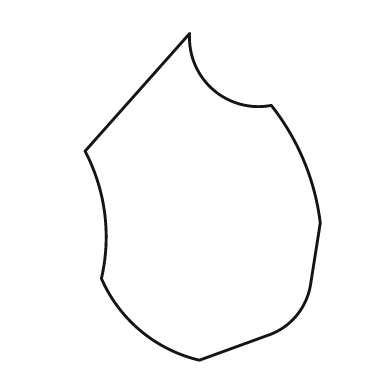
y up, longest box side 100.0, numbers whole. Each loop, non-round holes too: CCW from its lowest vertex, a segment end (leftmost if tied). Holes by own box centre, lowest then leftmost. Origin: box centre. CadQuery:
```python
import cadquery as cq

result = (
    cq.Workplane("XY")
    .moveTo(-1.0, -50.0)
    .lineTo(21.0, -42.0)
    .threePointArc((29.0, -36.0), (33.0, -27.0))
    .lineTo(36.0, -8.0)
    .threePointArc((31.0, 11.0), (21.0, 28.0))
    .threePointArc((3.0, 33.0), (-4.0, 50.0))
    .lineTo(-36.0, 14.0)
    .threePointArc((-30.0, -5.0), (-31.0, -25.0))
    .threePointArc((-19.0, -41.0), (-1.0, -50.0))
    .close()
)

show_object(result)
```